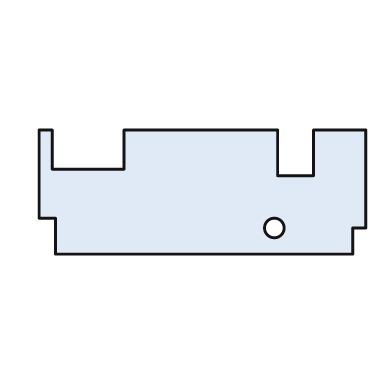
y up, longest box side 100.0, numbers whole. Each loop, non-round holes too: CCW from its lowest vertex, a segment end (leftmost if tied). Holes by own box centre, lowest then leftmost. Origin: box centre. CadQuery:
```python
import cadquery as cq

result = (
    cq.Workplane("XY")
    .moveTo(-45.0, -19.0)
    .lineTo(46.0, -19.0)
    .lineTo(46.0, -11.0)
    .lineTo(50.0, -11.0)
    .lineTo(50.0, 19.0)
    .lineTo(34.0, 19.0)
    .lineTo(34.0, 5.0)
    .lineTo(23.0, 5.0)
    .lineTo(23.0, 19.0)
    .lineTo(-24.0, 19.0)
    .lineTo(-24.0, 7.0)
    .lineTo(-46.0, 7.0)
    .lineTo(-46.0, 19.0)
    .lineTo(-50.0, 19.0)
    .lineTo(-50.0, -8.0)
    .lineTo(-45.0, -8.0)
    .close()
    .moveTo(22.0, -11.0)
    .circle(3.0)
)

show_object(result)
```